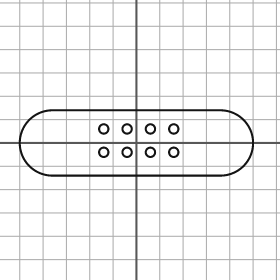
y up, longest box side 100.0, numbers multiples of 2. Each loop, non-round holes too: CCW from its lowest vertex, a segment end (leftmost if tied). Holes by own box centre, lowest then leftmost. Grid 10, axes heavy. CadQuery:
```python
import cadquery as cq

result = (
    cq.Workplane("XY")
    .moveTo(-36.0, -14.0)
    .lineTo(36.0, -14.0)
    .threePointArc((50.0, 0.0), (36.0, 14.0))
    .lineTo(-36.0, 14.0)
    .threePointArc((-50.0, 0.0), (-36.0, -14.0))
    .close()
    .moveTo(-14.0, -4.0)
    .circle(2.0)
    .moveTo(-4.0, -4.0)
    .circle(2.0)
    .moveTo(6.0, -4.0)
    .circle(2.0)
    .moveTo(16.0, -4.0)
    .circle(2.0)
    .moveTo(-14.0, 6.0)
    .circle(2.0)
    .moveTo(-4.0, 6.0)
    .circle(2.0)
    .moveTo(6.0, 6.0)
    .circle(2.0)
    .moveTo(16.0, 6.0)
    .circle(2.0)
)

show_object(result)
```